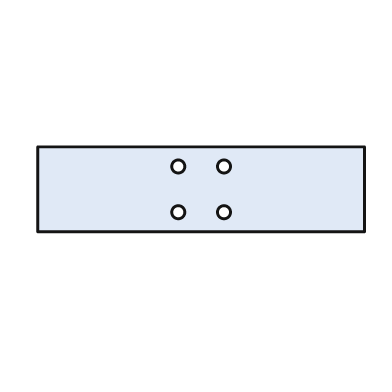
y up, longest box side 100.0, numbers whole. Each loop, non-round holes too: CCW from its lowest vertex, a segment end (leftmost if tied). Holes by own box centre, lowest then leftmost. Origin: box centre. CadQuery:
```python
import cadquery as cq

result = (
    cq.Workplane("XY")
    .moveTo(-50.0, -13.0)
    .lineTo(50.0, -13.0)
    .lineTo(50.0, 13.0)
    .lineTo(-50.0, 13.0)
    .close()
    .moveTo(-7.0, -7.0)
    .circle(2.0)
    .moveTo(7.0, -7.0)
    .circle(2.0)
    .moveTo(-7.0, 7.0)
    .circle(2.0)
    .moveTo(7.0, 7.0)
    .circle(2.0)
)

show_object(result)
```